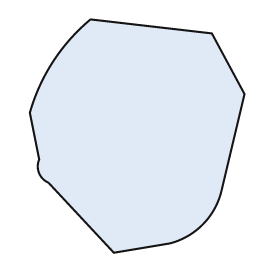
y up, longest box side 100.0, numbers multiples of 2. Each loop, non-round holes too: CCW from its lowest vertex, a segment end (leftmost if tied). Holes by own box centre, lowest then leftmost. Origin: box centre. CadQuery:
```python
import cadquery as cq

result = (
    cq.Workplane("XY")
    .moveTo(-10.0, -50.0)
    .lineTo(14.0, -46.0)
    .threePointArc((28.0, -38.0), (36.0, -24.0))
    .lineTo(46.0, 18.0)
    .lineTo(32.0, 44.0)
    .lineTo(-20.0, 50.0)
    .threePointArc((-36.0, 32.0), (-46.0, 10.0))
    .lineTo(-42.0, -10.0)
    .threePointArc((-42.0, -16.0), (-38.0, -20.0))
    .close()
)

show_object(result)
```